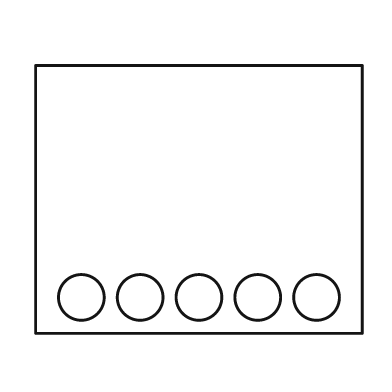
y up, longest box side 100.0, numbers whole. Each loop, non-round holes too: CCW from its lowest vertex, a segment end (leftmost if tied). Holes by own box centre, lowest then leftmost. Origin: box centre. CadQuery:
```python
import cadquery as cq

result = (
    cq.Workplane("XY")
    .moveTo(-50.0, -41.0)
    .lineTo(50.0, -41.0)
    .lineTo(50.0, 41.0)
    .lineTo(-50.0, 41.0)
    .close()
    .moveTo(-36.0, -30.0)
    .circle(7.0)
    .moveTo(-18.0, -30.0)
    .circle(7.0)
    .moveTo(0.0, -30.0)
    .circle(7.0)
    .moveTo(18.0, -30.0)
    .circle(7.0)
    .moveTo(36.0, -30.0)
    .circle(7.0)
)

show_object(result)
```